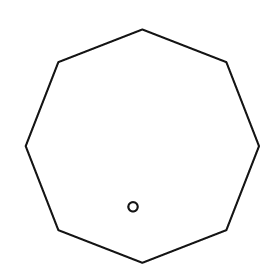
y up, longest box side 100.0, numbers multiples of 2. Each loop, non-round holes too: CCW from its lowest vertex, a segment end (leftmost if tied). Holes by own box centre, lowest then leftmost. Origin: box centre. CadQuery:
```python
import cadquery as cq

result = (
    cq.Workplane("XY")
    .moveTo(0.0, -50.0)
    .lineTo(36.0, -36.0)
    .lineTo(50.0, 0.0)
    .lineTo(36.0, 36.0)
    .lineTo(0.0, 50.0)
    .lineTo(-36.0, 36.0)
    .lineTo(-50.0, 0.0)
    .lineTo(-36.0, -36.0)
    .close()
    .moveTo(-4.0, -26.0)
    .circle(2.0)
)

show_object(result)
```